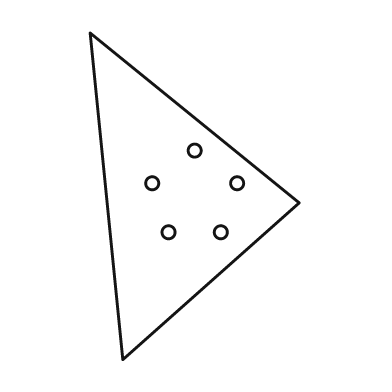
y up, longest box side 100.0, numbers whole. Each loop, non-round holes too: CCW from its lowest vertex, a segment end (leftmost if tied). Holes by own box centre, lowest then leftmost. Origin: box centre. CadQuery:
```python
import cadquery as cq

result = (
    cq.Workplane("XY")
    .moveTo(-22.0, -50.0)
    .lineTo(32.0, -2.0)
    .lineTo(-32.0, 50.0)
    .close()
    .moveTo(-8.0, -11.0)
    .circle(2.0)
    .moveTo(8.0, -11.0)
    .circle(2.0)
    .moveTo(-13.0, 4.0)
    .circle(2.0)
    .moveTo(13.0, 4.0)
    .circle(2.0)
    .moveTo(0.0, 14.0)
    .circle(2.0)
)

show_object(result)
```